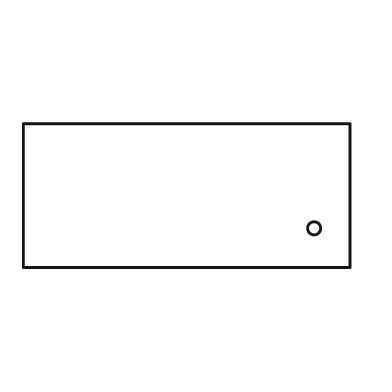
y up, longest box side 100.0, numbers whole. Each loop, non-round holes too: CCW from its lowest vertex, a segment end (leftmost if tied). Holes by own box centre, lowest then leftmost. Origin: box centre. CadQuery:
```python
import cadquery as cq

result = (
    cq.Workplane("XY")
    .moveTo(-50.0, -22.0)
    .lineTo(50.0, -22.0)
    .lineTo(50.0, 22.0)
    .lineTo(-50.0, 22.0)
    .close()
    .moveTo(39.0, -10.0)
    .circle(2.0)
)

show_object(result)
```